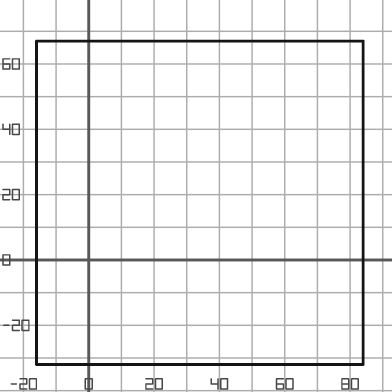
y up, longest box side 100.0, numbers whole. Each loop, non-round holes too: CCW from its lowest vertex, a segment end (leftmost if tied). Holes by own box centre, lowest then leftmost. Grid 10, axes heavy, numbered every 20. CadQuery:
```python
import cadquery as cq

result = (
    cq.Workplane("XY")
    .moveTo(-16.0, -32.0)
    .lineTo(84.0, -32.0)
    .lineTo(84.0, 67.0)
    .lineTo(-16.0, 67.0)
    .close()
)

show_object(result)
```